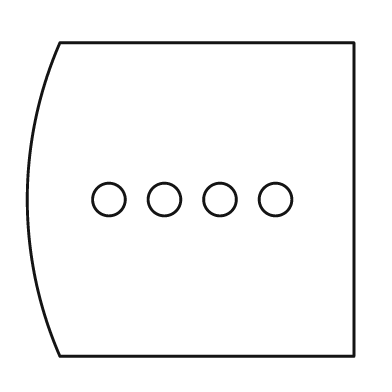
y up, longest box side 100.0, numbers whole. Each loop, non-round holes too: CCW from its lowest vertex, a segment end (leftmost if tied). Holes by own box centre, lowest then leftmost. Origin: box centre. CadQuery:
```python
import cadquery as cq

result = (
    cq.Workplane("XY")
    .moveTo(-40.0, -48.0)
    .lineTo(50.0, -48.0)
    .lineTo(50.0, 48.0)
    .lineTo(-40.0, 48.0)
    .threePointArc((-50.0, 0.0), (-40.0, -48.0))
    .close()
    .moveTo(-25.0, 0.0)
    .circle(5.0)
    .moveTo(-8.0, 0.0)
    .circle(5.0)
    .moveTo(9.0, 0.0)
    .circle(5.0)
    .moveTo(26.0, 0.0)
    .circle(5.0)
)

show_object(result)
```